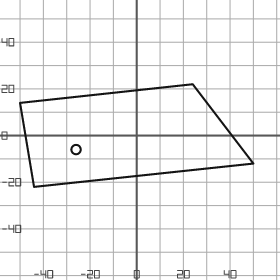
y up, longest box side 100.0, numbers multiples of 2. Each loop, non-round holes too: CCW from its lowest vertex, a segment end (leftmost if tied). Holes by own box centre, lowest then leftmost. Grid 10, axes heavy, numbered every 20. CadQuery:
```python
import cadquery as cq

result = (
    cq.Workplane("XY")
    .moveTo(-44.0, -22.0)
    .lineTo(50.0, -12.0)
    .lineTo(24.0, 22.0)
    .lineTo(-50.0, 14.0)
    .close()
    .moveTo(-26.0, -6.0)
    .circle(2.0)
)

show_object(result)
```